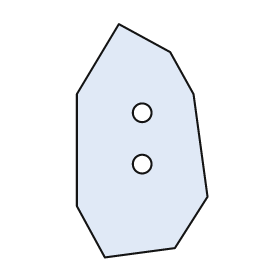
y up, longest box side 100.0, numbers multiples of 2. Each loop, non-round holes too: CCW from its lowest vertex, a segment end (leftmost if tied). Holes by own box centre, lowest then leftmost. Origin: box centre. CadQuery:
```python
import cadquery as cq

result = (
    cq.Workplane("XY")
    .moveTo(-16.0, -50.0)
    .lineTo(14.0, -46.0)
    .lineTo(28.0, -24.0)
    .lineTo(22.0, 20.0)
    .lineTo(12.0, 38.0)
    .lineTo(-10.0, 50.0)
    .lineTo(-28.0, 20.0)
    .lineTo(-28.0, -28.0)
    .close()
    .moveTo(0.0, -10.0)
    .circle(4.0)
    .moveTo(0.0, 12.0)
    .circle(4.0)
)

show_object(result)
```